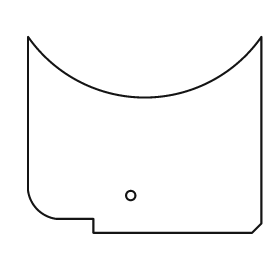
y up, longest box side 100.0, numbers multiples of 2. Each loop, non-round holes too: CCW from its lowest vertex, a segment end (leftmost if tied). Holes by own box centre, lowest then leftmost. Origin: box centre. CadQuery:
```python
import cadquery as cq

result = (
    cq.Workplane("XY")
    .moveTo(-22.0, -42.0)
    .lineTo(46.0, -42.0)
    .lineTo(50.0, -38.0)
    .lineTo(50.0, 42.0)
    .threePointArc((0.0, 16.0), (-50.0, 42.0))
    .lineTo(-50.0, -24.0)
    .threePointArc((-46.0, -32.0), (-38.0, -36.0))
    .lineTo(-22.0, -36.0)
    .close()
    .moveTo(-6.0, -26.0)
    .circle(2.0)
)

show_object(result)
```